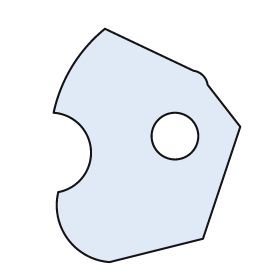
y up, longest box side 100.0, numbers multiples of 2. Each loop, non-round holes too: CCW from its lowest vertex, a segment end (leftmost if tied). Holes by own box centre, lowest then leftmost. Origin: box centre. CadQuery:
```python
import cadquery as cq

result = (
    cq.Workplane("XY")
    .moveTo(-16.0, -50.0)
    .lineTo(24.0, -40.0)
    .lineTo(40.0, 8.0)
    .lineTo(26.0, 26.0)
    .threePointArc((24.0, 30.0), (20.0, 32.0))
    .lineTo(-18.0, 50.0)
    .threePointArc((-32.0, 34.0), (-40.0, 14.0))
    .threePointArc((-24.0, -2.0), (-38.0, -20.0))
    .threePointArc((-34.0, -40.0), (-16.0, -50.0))
    .close()
    .moveTo(12.0, 4.0)
    .circle(10.0)
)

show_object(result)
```